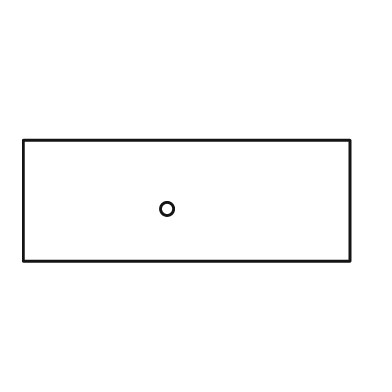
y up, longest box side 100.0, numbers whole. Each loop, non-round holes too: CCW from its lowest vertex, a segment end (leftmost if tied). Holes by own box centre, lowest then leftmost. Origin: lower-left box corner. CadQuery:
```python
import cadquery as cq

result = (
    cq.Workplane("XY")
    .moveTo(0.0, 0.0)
    .lineTo(100.0, 0.0)
    .lineTo(100.0, 37.0)
    .lineTo(0.0, 37.0)
    .close()
    .moveTo(44.0, 16.0)
    .circle(2.0)
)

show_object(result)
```